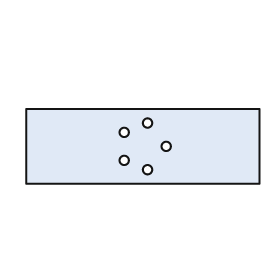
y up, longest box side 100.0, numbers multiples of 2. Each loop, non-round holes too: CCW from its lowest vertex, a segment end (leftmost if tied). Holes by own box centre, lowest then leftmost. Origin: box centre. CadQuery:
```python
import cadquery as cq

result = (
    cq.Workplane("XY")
    .moveTo(-50.0, -16.0)
    .lineTo(50.0, -16.0)
    .lineTo(50.0, 16.0)
    .lineTo(-50.0, 16.0)
    .close()
    .moveTo(2.0, -10.0)
    .circle(2.0)
    .moveTo(-8.0, -6.0)
    .circle(2.0)
    .moveTo(10.0, 0.0)
    .circle(2.0)
    .moveTo(-8.0, 6.0)
    .circle(2.0)
    .moveTo(2.0, 10.0)
    .circle(2.0)
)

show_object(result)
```